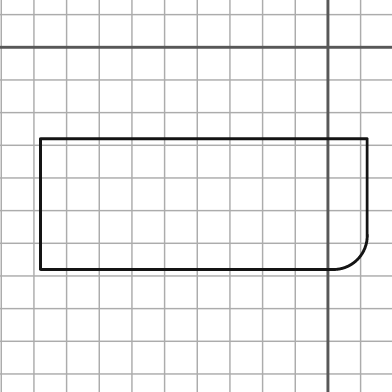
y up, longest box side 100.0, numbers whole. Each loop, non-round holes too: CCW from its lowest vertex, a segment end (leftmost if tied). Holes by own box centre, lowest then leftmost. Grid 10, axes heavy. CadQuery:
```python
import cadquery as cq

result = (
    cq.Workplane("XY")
    .moveTo(-88.0, -68.0)
    .lineTo(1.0, -68.0)
    .threePointArc((9.0, -65.0), (12.0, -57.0))
    .lineTo(12.0, -28.0)
    .lineTo(-88.0, -28.0)
    .close()
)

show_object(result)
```